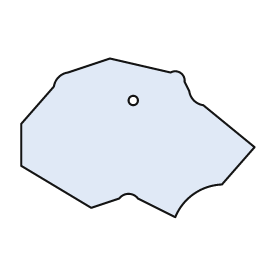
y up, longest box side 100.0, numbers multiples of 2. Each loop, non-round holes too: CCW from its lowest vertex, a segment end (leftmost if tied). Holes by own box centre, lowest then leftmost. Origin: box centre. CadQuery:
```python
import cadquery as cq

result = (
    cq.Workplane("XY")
    .moveTo(16.0, -34.0)
    .threePointArc((24.0, -24.0), (36.0, -20.0))
    .lineTo(50.0, -4.0)
    .lineTo(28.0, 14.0)
    .threePointArc((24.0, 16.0), (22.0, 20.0))
    .lineTo(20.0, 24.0)
    .threePointArc((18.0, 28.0), (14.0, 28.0))
    .lineTo(-12.0, 34.0)
    .lineTo(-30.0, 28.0)
    .threePointArc((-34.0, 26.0), (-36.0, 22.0))
    .lineTo(-50.0, 6.0)
    .lineTo(-50.0, -12.0)
    .lineTo(-20.0, -30.0)
    .lineTo(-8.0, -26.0)
    .threePointArc((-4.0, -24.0), (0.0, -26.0))
    .close()
    .moveTo(-2.0, 16.0)
    .circle(2.0)
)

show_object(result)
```